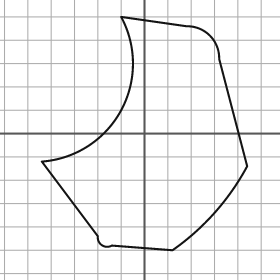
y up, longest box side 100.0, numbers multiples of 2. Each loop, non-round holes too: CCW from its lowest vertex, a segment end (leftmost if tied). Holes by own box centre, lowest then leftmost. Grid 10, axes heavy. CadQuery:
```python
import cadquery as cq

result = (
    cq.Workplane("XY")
    .moveTo(12.0, -50.0)
    .threePointArc((30.0, -34.0), (44.0, -14.0))
    .lineTo(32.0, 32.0)
    .threePointArc((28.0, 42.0), (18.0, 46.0))
    .lineTo(-10.0, 50.0)
    .threePointArc((-10.0, 10.0), (-44.0, -12.0))
    .lineTo(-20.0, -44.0)
    .threePointArc((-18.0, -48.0), (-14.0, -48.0))
    .close()
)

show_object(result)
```